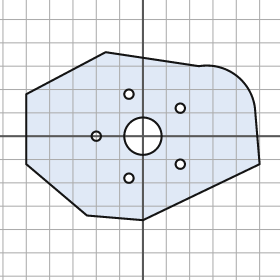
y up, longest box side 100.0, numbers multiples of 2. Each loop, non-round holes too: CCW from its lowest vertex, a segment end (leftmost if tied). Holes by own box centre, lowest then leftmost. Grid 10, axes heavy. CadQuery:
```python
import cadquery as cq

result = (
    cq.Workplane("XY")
    .moveTo(0.0, -36.0)
    .lineTo(50.0, -12.0)
    .lineTo(48.0, 12.0)
    .threePointArc((40.0, 26.0), (24.0, 30.0))
    .lineTo(-16.0, 36.0)
    .lineTo(-50.0, 18.0)
    .lineTo(-50.0, -12.0)
    .lineTo(-24.0, -34.0)
    .close()
    .moveTo(-6.0, -18.0)
    .circle(2.0)
    .moveTo(16.0, -12.0)
    .circle(2.0)
    .moveTo(-20.0, 0.0)
    .circle(2.0)
    .moveTo(0.0, 0.0)
    .circle(8.0)
    .moveTo(16.0, 12.0)
    .circle(2.0)
    .moveTo(-6.0, 18.0)
    .circle(2.0)
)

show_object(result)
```